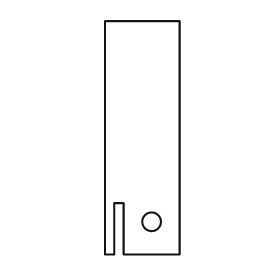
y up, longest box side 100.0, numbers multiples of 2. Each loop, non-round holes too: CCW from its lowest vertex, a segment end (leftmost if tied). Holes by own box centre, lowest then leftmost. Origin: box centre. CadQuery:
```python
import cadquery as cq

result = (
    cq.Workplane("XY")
    .moveTo(-16.0, -50.0)
    .lineTo(-12.0, -50.0)
    .lineTo(-12.0, -28.0)
    .lineTo(-8.0, -28.0)
    .lineTo(-8.0, -50.0)
    .lineTo(16.0, -50.0)
    .lineTo(16.0, 50.0)
    .lineTo(-16.0, 50.0)
    .close()
    .moveTo(4.0, -36.0)
    .circle(4.0)
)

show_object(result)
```